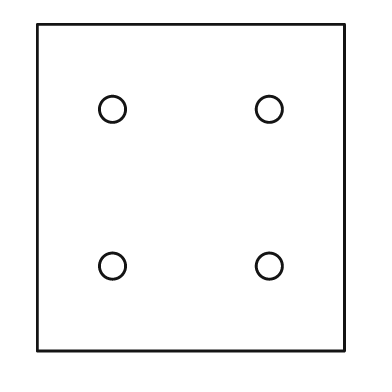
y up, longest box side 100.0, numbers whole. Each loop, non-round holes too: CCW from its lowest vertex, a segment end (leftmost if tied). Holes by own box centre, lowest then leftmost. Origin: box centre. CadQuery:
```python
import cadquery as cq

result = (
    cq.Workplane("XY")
    .moveTo(-47.0, -50.0)
    .lineTo(47.0, -50.0)
    .lineTo(47.0, 50.0)
    .lineTo(-47.0, 50.0)
    .close()
    .moveTo(-24.0, -24.0)
    .circle(4.0)
    .moveTo(24.0, -24.0)
    .circle(4.0)
    .moveTo(-24.0, 24.0)
    .circle(4.0)
    .moveTo(24.0, 24.0)
    .circle(4.0)
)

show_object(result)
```